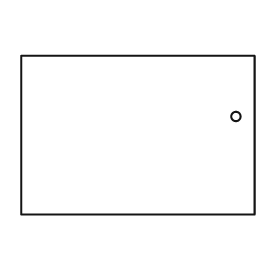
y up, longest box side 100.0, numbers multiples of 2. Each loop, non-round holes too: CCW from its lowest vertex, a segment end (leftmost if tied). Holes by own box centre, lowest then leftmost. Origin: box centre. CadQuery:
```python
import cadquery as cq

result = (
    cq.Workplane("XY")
    .moveTo(-50.0, -34.0)
    .lineTo(50.0, -34.0)
    .lineTo(50.0, 34.0)
    .lineTo(-50.0, 34.0)
    .close()
    .moveTo(42.0, 8.0)
    .circle(2.0)
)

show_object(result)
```